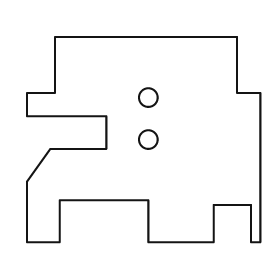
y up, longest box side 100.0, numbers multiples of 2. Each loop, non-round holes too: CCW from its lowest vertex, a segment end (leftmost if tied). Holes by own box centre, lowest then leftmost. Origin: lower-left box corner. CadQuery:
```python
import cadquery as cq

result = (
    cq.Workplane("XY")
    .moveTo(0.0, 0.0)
    .lineTo(14.0, 0.0)
    .lineTo(14.0, 18.0)
    .lineTo(52.0, 18.0)
    .lineTo(52.0, 0.0)
    .lineTo(80.0, 0.0)
    .lineTo(80.0, 16.0)
    .lineTo(96.0, 16.0)
    .lineTo(96.0, 0.0)
    .lineTo(100.0, 0.0)
    .lineTo(100.0, 64.0)
    .lineTo(90.0, 64.0)
    .lineTo(90.0, 88.0)
    .lineTo(12.0, 88.0)
    .lineTo(12.0, 64.0)
    .lineTo(0.0, 64.0)
    .lineTo(0.0, 54.0)
    .lineTo(34.0, 54.0)
    .lineTo(34.0, 40.0)
    .lineTo(10.0, 40.0)
    .lineTo(0.0, 26.0)
    .close()
    .moveTo(52.0, 44.0)
    .circle(4.0)
    .moveTo(52.0, 62.0)
    .circle(4.0)
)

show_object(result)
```